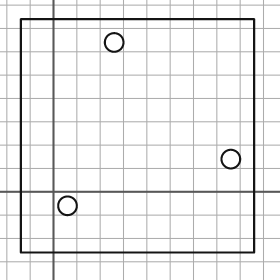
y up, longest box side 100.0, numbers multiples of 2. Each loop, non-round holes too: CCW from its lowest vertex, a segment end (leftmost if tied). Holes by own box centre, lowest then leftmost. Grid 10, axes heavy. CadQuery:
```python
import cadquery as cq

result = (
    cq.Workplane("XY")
    .moveTo(-14.0, -26.0)
    .lineTo(86.0, -26.0)
    .lineTo(86.0, 74.0)
    .lineTo(-14.0, 74.0)
    .close()
    .moveTo(6.0, -6.0)
    .circle(4.0)
    .moveTo(76.0, 14.0)
    .circle(4.0)
    .moveTo(26.0, 64.0)
    .circle(4.0)
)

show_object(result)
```